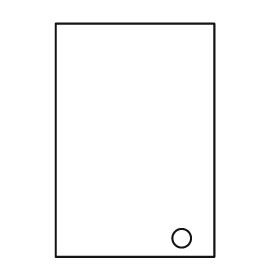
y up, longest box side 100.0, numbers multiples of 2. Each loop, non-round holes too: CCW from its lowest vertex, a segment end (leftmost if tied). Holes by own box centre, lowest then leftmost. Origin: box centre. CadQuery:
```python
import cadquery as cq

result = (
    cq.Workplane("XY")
    .moveTo(-34.0, -50.0)
    .lineTo(34.0, -50.0)
    .lineTo(34.0, 50.0)
    .lineTo(-34.0, 50.0)
    .close()
    .moveTo(20.0, -42.0)
    .circle(4.0)
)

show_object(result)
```